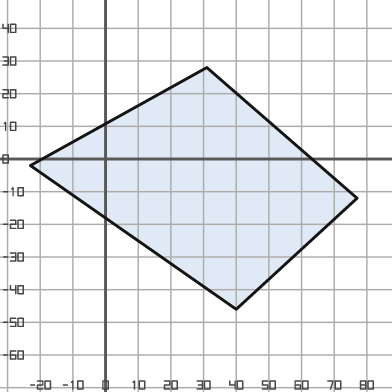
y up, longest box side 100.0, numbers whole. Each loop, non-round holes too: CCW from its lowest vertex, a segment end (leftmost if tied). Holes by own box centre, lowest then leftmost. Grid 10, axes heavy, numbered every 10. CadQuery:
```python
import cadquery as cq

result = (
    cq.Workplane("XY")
    .moveTo(40.0, -46.0)
    .lineTo(77.0, -12.0)
    .lineTo(31.0, 28.0)
    .lineTo(-23.0, -2.0)
    .close()
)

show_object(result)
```